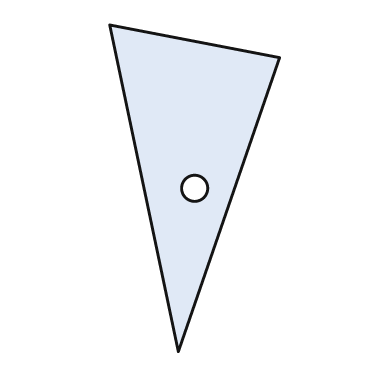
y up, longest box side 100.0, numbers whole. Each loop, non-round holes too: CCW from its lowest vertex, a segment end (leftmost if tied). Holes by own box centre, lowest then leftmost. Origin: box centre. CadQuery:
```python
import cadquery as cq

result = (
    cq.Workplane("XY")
    .moveTo(-5.0, -50.0)
    .lineTo(26.0, 40.0)
    .lineTo(-26.0, 50.0)
    .close()
    .moveTo(0.0, 0.0)
    .circle(4.0)
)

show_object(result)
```